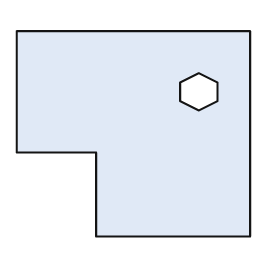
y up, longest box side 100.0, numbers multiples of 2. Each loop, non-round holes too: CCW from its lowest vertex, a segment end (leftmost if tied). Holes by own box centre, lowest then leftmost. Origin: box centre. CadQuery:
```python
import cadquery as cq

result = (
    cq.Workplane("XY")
    .moveTo(-16.0, -44.0)
    .lineTo(50.0, -44.0)
    .lineTo(50.0, 44.0)
    .lineTo(-50.0, 44.0)
    .lineTo(-50.0, -8.0)
    .lineTo(-16.0, -8.0)
    .close()
    .moveTo(28.0, 10.0)
    .lineTo(36.0, 14.0)
    .lineTo(36.0, 22.0)
    .lineTo(28.0, 26.0)
    .lineTo(20.0, 22.0)
    .lineTo(20.0, 14.0)
    .close()
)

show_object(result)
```